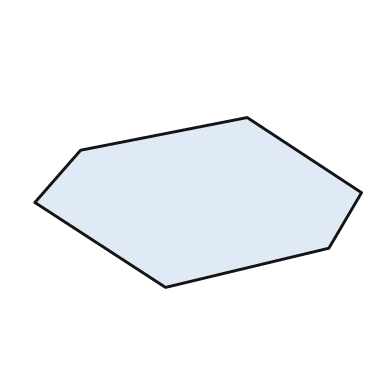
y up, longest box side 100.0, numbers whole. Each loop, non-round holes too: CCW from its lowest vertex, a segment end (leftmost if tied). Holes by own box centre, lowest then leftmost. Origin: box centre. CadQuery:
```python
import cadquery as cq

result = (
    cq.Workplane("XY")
    .moveTo(-10.0, -26.0)
    .lineTo(40.0, -14.0)
    .lineTo(50.0, 3.0)
    .lineTo(15.0, 26.0)
    .lineTo(-36.0, 16.0)
    .lineTo(-50.0, 0.0)
    .close()
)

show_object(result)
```